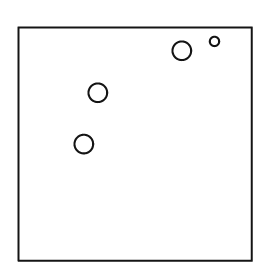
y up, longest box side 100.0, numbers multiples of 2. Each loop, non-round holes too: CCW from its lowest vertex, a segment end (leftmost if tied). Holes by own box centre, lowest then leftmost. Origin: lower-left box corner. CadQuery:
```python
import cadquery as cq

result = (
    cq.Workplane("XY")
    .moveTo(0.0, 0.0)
    .lineTo(100.0, 0.0)
    .lineTo(100.0, 100.0)
    .lineTo(0.0, 100.0)
    .close()
    .moveTo(28.0, 50.0)
    .circle(4.0)
    .moveTo(34.0, 72.0)
    .circle(4.0)
    .moveTo(70.0, 90.0)
    .circle(4.0)
    .moveTo(84.0, 94.0)
    .circle(2.0)
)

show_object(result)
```